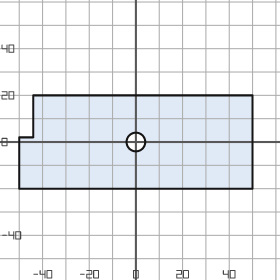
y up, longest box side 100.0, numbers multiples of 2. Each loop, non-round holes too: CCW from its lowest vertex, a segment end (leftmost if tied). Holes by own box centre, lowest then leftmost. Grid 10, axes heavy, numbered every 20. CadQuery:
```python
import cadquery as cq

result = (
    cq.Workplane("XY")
    .moveTo(-50.0, -20.0)
    .lineTo(50.0, -20.0)
    .lineTo(50.0, 20.0)
    .lineTo(-44.0, 20.0)
    .lineTo(-44.0, 2.0)
    .lineTo(-50.0, 2.0)
    .close()
    .moveTo(0.0, 0.0)
    .circle(4.0)
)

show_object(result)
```